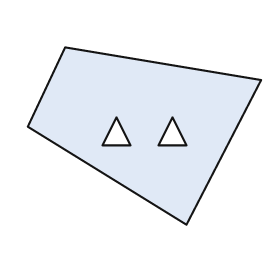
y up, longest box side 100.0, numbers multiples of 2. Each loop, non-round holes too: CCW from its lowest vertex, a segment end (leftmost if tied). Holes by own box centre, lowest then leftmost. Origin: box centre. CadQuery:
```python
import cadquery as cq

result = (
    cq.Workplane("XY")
    .moveTo(18.0, -38.0)
    .lineTo(50.0, 24.0)
    .lineTo(-34.0, 38.0)
    .lineTo(-50.0, 4.0)
    .close()
    .moveTo(-18.0, -4.0)
    .lineTo(-6.0, -4.0)
    .lineTo(-12.0, 8.0)
    .close()
    .moveTo(6.0, -4.0)
    .lineTo(18.0, -4.0)
    .lineTo(12.0, 8.0)
    .close()
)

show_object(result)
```